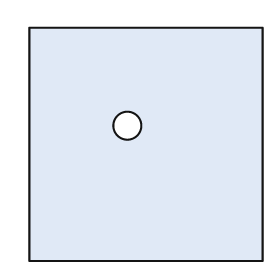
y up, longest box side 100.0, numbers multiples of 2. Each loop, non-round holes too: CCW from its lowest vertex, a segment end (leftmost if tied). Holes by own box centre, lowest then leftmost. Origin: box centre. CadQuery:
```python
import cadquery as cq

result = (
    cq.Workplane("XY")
    .moveTo(-50.0, -50.0)
    .lineTo(50.0, -50.0)
    .lineTo(50.0, 50.0)
    .lineTo(-50.0, 50.0)
    .close()
    .moveTo(-8.0, 8.0)
    .circle(6.0)
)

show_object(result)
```